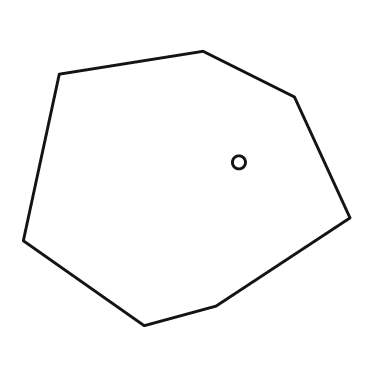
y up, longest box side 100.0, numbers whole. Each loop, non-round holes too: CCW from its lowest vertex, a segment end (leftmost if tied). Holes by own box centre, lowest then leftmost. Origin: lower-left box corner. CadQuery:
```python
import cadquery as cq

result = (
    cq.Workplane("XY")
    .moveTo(37.0, 0.0)
    .lineTo(59.0, 6.0)
    .lineTo(100.0, 33.0)
    .lineTo(83.0, 70.0)
    .lineTo(55.0, 84.0)
    .lineTo(11.0, 77.0)
    .lineTo(0.0, 26.0)
    .close()
    .moveTo(66.0, 50.0)
    .circle(2.0)
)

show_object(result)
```